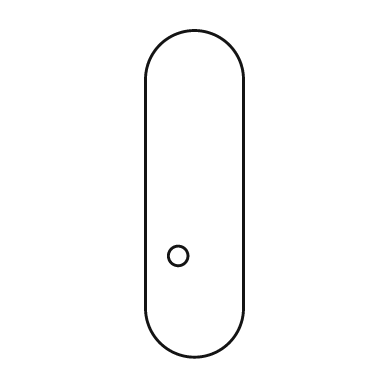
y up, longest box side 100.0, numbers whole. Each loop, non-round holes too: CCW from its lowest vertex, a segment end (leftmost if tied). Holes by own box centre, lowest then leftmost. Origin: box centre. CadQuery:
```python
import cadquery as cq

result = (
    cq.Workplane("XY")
    .moveTo(-15.0, -35.0)
    .threePointArc((0.0, -50.0), (15.0, -35.0))
    .lineTo(15.0, 35.0)
    .threePointArc((0.0, 50.0), (-15.0, 35.0))
    .close()
    .moveTo(-5.0, -19.0)
    .circle(3.0)
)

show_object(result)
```